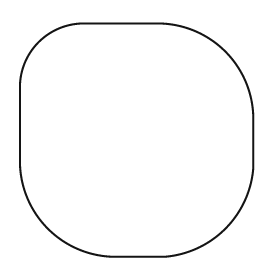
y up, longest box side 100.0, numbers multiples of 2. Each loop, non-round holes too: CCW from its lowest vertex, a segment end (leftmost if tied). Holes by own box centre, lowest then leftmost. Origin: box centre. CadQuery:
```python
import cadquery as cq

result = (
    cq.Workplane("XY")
    .moveTo(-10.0, -50.0)
    .lineTo(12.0, -50.0)
    .threePointArc((38.0, -38.0), (50.0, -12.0))
    .lineTo(50.0, 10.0)
    .threePointArc((38.0, 38.0), (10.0, 50.0))
    .lineTo(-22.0, 50.0)
    .threePointArc((-42.0, 42.0), (-50.0, 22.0))
    .lineTo(-50.0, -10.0)
    .threePointArc((-38.0, -38.0), (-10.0, -50.0))
    .close()
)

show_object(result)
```